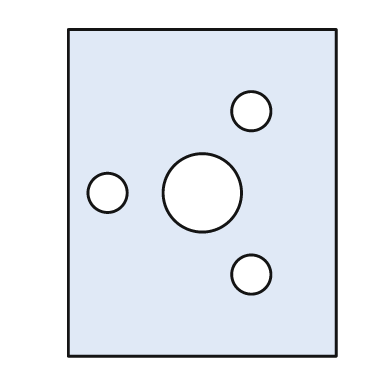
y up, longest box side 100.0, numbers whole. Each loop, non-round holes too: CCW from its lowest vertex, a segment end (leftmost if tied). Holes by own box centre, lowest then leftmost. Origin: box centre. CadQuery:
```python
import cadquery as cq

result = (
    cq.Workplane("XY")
    .moveTo(-41.0, -50.0)
    .lineTo(41.0, -50.0)
    .lineTo(41.0, 50.0)
    .lineTo(-41.0, 50.0)
    .close()
    .moveTo(15.0, -25.0)
    .circle(6.0)
    .moveTo(-29.0, 0.0)
    .circle(6.0)
    .moveTo(0.0, 0.0)
    .circle(12.0)
    .moveTo(15.0, 25.0)
    .circle(6.0)
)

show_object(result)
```